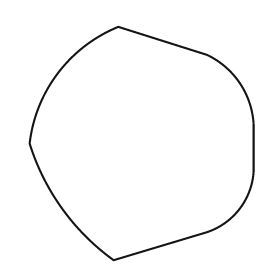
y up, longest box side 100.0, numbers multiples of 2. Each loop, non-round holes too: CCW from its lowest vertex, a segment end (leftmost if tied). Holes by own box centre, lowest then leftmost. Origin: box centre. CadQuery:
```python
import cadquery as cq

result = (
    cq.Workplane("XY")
    .moveTo(-12.0, -50.0)
    .lineTo(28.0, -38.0)
    .threePointArc((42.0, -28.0), (48.0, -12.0))
    .lineTo(48.0, 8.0)
    .threePointArc((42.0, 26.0), (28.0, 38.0))
    .lineTo(-10.0, 50.0)
    .threePointArc((-36.0, 30.0), (-48.0, 0.0))
    .threePointArc((-34.0, -28.0), (-12.0, -50.0))
    .close()
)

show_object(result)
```